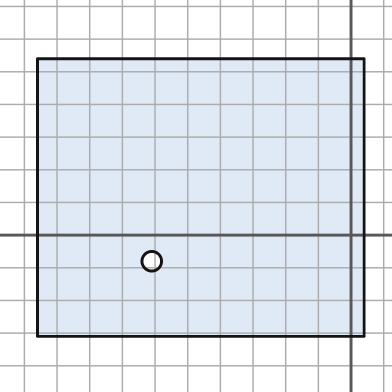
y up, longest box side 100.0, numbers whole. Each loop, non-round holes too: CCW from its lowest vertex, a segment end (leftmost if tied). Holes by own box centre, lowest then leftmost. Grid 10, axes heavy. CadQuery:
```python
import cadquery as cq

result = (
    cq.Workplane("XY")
    .moveTo(-96.0, -31.0)
    .lineTo(4.0, -31.0)
    .lineTo(4.0, 54.0)
    .lineTo(-96.0, 54.0)
    .close()
    .moveTo(-61.0, -8.0)
    .circle(3.0)
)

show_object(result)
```